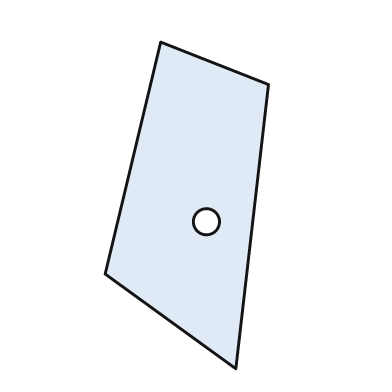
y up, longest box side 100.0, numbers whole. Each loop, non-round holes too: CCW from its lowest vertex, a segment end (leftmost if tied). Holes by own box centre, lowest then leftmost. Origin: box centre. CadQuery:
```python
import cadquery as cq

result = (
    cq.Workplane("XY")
    .moveTo(15.0, -50.0)
    .lineTo(25.0, 37.0)
    .lineTo(-8.0, 50.0)
    .lineTo(-25.0, -21.0)
    .close()
    .moveTo(6.0, -5.0)
    .circle(4.0)
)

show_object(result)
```